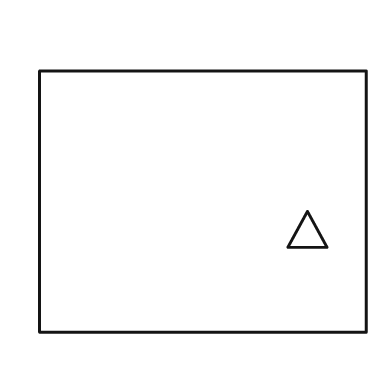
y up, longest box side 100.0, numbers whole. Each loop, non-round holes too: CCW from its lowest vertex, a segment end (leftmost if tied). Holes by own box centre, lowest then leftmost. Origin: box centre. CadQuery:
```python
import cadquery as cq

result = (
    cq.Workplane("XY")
    .moveTo(-50.0, -40.0)
    .lineTo(50.0, -40.0)
    .lineTo(50.0, 40.0)
    .lineTo(-50.0, 40.0)
    .close()
    .moveTo(26.0, -14.0)
    .lineTo(38.0, -14.0)
    .lineTo(32.0, -3.0)
    .close()
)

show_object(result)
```